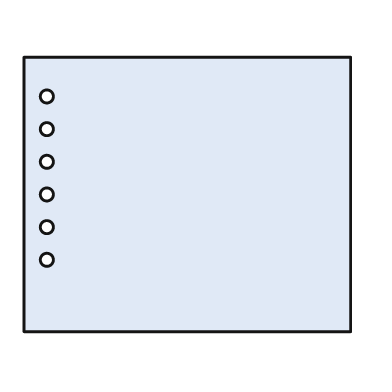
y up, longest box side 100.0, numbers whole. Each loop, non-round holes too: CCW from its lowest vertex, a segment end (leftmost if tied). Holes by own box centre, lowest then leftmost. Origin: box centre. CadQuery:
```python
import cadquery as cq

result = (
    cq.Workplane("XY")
    .moveTo(-50.0, -42.0)
    .lineTo(50.0, -42.0)
    .lineTo(50.0, 42.0)
    .lineTo(-50.0, 42.0)
    .close()
    .moveTo(-43.0, -20.0)
    .circle(2.0)
    .moveTo(-43.0, -10.0)
    .circle(2.0)
    .moveTo(-43.0, 0.0)
    .circle(2.0)
    .moveTo(-43.0, 10.0)
    .circle(2.0)
    .moveTo(-43.0, 20.0)
    .circle(2.0)
    .moveTo(-43.0, 30.0)
    .circle(2.0)
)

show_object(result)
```